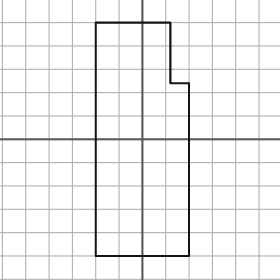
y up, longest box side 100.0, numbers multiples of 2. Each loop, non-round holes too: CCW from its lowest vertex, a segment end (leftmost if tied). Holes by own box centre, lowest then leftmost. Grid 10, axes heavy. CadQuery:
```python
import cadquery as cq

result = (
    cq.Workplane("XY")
    .moveTo(-20.0, -50.0)
    .lineTo(20.0, -50.0)
    .lineTo(20.0, 24.0)
    .lineTo(12.0, 24.0)
    .lineTo(12.0, 50.0)
    .lineTo(-20.0, 50.0)
    .close()
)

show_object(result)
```